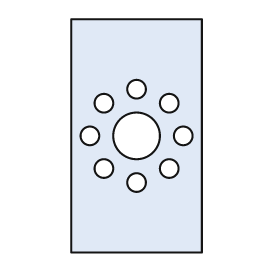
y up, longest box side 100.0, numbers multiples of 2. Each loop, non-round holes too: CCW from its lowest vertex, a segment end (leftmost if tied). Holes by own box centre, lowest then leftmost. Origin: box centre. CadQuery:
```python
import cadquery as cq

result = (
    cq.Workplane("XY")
    .moveTo(-28.0, -50.0)
    .lineTo(28.0, -50.0)
    .lineTo(28.0, 50.0)
    .lineTo(-28.0, 50.0)
    .close()
    .moveTo(0.0, -20.0)
    .circle(4.0)
    .moveTo(-14.0, -14.0)
    .circle(4.0)
    .moveTo(14.0, -14.0)
    .circle(4.0)
    .moveTo(-20.0, 0.0)
    .circle(4.0)
    .moveTo(0.0, 0.0)
    .circle(10.0)
    .moveTo(20.0, 0.0)
    .circle(4.0)
    .moveTo(-14.0, 14.0)
    .circle(4.0)
    .moveTo(14.0, 14.0)
    .circle(4.0)
    .moveTo(0.0, 20.0)
    .circle(4.0)
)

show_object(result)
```